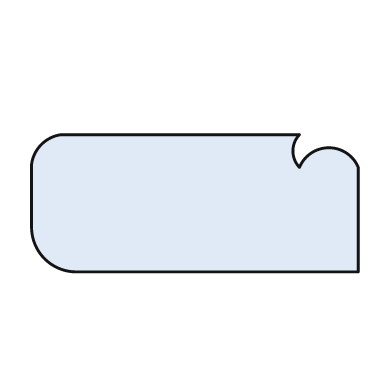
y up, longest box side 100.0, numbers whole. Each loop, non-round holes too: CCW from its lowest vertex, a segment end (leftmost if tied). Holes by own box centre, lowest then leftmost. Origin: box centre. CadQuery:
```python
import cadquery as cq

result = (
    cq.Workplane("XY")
    .moveTo(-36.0, -21.0)
    .lineTo(50.0, -21.0)
    .lineTo(50.0, 11.0)
    .threePointArc((41.0, 17.0), (32.0, 11.0))
    .threePointArc((30.0, 16.0), (32.0, 21.0))
    .lineTo(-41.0, 21.0)
    .threePointArc((-47.0, 18.0), (-50.0, 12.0))
    .lineTo(-50.0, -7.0)
    .threePointArc((-46.0, -17.0), (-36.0, -21.0))
    .close()
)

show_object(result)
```